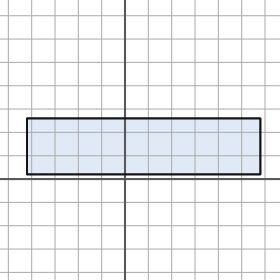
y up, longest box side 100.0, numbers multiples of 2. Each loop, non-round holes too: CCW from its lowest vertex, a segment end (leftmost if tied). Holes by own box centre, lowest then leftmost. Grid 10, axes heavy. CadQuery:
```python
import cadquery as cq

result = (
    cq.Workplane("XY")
    .moveTo(-42.0, 2.0)
    .lineTo(58.0, 2.0)
    .lineTo(58.0, 26.0)
    .lineTo(-42.0, 26.0)
    .close()
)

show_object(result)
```